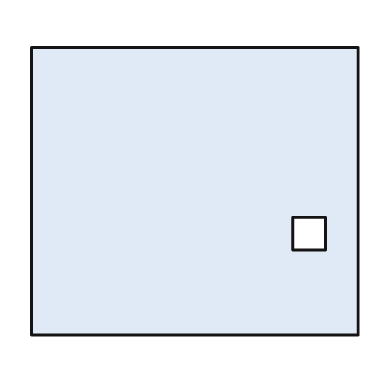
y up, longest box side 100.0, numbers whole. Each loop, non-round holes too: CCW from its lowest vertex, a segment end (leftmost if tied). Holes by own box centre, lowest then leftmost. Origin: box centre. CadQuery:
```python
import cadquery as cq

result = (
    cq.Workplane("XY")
    .moveTo(-50.0, -44.0)
    .lineTo(50.0, -44.0)
    .lineTo(50.0, 44.0)
    .lineTo(-50.0, 44.0)
    .close()
    .moveTo(30.0, -18.0)
    .lineTo(40.0, -18.0)
    .lineTo(40.0, -8.0)
    .lineTo(30.0, -8.0)
    .close()
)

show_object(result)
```